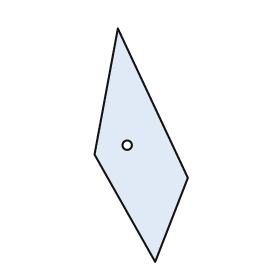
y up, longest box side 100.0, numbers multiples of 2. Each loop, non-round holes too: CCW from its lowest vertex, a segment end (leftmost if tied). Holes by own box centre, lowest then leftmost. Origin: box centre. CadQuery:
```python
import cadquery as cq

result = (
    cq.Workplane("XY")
    .moveTo(6.0, -50.0)
    .lineTo(20.0, -14.0)
    .lineTo(-10.0, 50.0)
    .lineTo(-20.0, -4.0)
    .close()
    .moveTo(-6.0, 0.0)
    .circle(2.0)
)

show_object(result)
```